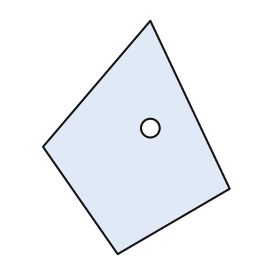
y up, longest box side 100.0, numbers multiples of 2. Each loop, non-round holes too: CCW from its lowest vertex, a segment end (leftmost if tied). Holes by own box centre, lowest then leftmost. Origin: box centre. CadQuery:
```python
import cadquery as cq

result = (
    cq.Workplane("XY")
    .moveTo(-8.0, -50.0)
    .lineTo(40.0, -22.0)
    .lineTo(6.0, 50.0)
    .lineTo(-40.0, -4.0)
    .close()
    .moveTo(6.0, 4.0)
    .circle(4.0)
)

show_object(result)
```